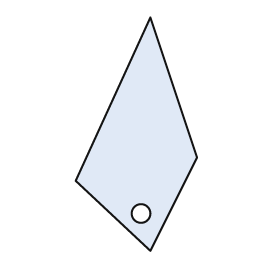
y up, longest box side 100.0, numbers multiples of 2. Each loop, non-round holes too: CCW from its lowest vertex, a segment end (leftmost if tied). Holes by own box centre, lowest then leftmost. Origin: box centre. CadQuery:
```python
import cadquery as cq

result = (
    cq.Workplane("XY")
    .moveTo(6.0, -50.0)
    .lineTo(26.0, -10.0)
    .lineTo(6.0, 50.0)
    .lineTo(-26.0, -20.0)
    .close()
    .moveTo(2.0, -34.0)
    .circle(4.0)
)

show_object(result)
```